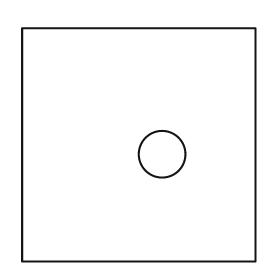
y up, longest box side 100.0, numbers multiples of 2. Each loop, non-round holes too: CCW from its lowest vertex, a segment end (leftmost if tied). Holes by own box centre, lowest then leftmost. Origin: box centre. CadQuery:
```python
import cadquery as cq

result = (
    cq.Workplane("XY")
    .moveTo(-50.0, -50.0)
    .lineTo(50.0, -50.0)
    .lineTo(50.0, 50.0)
    .lineTo(-50.0, 50.0)
    .close()
    .moveTo(10.0, -4.0)
    .circle(10.0)
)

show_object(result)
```